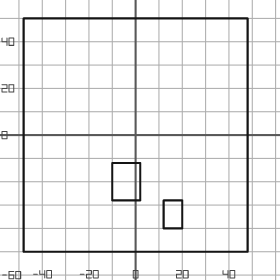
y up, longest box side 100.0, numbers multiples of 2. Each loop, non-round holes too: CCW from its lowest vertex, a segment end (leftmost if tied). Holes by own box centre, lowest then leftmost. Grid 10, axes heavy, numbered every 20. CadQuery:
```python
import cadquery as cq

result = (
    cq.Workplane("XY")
    .moveTo(-48.0, -50.0)
    .lineTo(48.0, -50.0)
    .lineTo(48.0, 50.0)
    .lineTo(-48.0, 50.0)
    .close()
    .moveTo(12.0, -40.0)
    .lineTo(20.0, -40.0)
    .lineTo(20.0, -28.0)
    .lineTo(12.0, -28.0)
    .close()
    .moveTo(-10.0, -28.0)
    .lineTo(2.0, -28.0)
    .lineTo(2.0, -12.0)
    .lineTo(-10.0, -12.0)
    .close()
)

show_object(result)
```